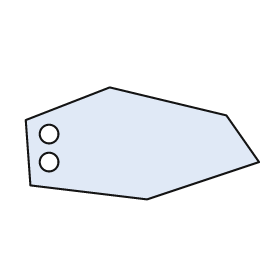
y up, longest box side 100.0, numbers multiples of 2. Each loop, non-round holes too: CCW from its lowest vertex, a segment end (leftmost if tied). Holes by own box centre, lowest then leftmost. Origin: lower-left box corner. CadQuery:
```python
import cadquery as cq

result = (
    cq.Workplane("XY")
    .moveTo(52.0, 0.0)
    .lineTo(100.0, 16.0)
    .lineTo(86.0, 36.0)
    .lineTo(36.0, 48.0)
    .lineTo(0.0, 34.0)
    .lineTo(2.0, 6.0)
    .close()
    .moveTo(10.0, 16.0)
    .circle(4.0)
    .moveTo(10.0, 28.0)
    .circle(4.0)
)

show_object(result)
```